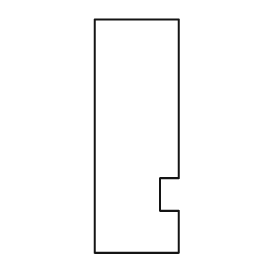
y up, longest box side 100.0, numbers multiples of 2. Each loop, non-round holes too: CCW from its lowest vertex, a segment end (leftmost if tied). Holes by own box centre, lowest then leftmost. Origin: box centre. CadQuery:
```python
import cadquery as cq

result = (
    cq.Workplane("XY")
    .moveTo(-18.0, -50.0)
    .lineTo(18.0, -50.0)
    .lineTo(18.0, -32.0)
    .lineTo(10.0, -32.0)
    .lineTo(10.0, -18.0)
    .lineTo(18.0, -18.0)
    .lineTo(18.0, 50.0)
    .lineTo(-18.0, 50.0)
    .close()
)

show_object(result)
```